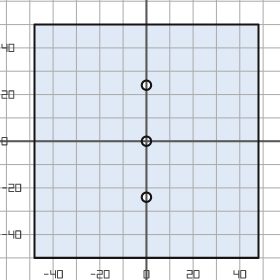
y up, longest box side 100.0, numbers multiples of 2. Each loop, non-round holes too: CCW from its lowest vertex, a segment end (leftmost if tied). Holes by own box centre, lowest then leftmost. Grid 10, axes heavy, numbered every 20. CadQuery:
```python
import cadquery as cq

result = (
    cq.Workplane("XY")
    .moveTo(-48.0, -50.0)
    .lineTo(48.0, -50.0)
    .lineTo(48.0, 50.0)
    .lineTo(-48.0, 50.0)
    .close()
    .moveTo(0.0, -24.0)
    .circle(2.0)
    .moveTo(0.0, 0.0)
    .circle(2.0)
    .moveTo(0.0, 24.0)
    .circle(2.0)
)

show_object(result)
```